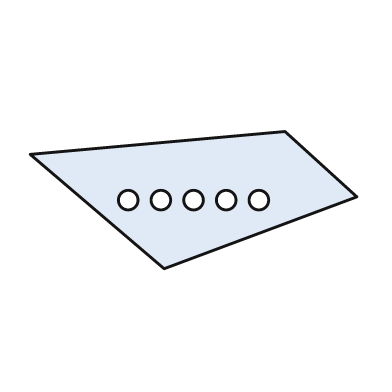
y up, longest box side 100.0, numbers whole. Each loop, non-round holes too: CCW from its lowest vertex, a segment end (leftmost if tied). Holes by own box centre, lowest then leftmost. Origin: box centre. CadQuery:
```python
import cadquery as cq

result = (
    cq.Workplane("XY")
    .moveTo(-9.0, -21.0)
    .lineTo(50.0, 1.0)
    .lineTo(28.0, 21.0)
    .lineTo(-50.0, 14.0)
    .close()
    .moveTo(-20.0, 0.0)
    .circle(3.0)
    .moveTo(-10.0, 0.0)
    .circle(3.0)
    .moveTo(0.0, 0.0)
    .circle(3.0)
    .moveTo(10.0, 0.0)
    .circle(3.0)
    .moveTo(20.0, 0.0)
    .circle(3.0)
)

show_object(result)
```